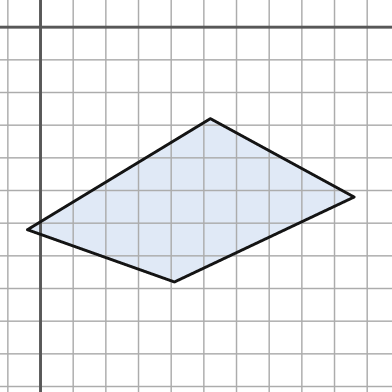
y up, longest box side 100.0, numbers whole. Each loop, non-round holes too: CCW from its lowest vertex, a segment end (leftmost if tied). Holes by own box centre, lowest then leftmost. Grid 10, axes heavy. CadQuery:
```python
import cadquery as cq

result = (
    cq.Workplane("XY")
    .moveTo(41.0, -78.0)
    .lineTo(96.0, -52.0)
    .lineTo(52.0, -28.0)
    .lineTo(-4.0, -62.0)
    .close()
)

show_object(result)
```